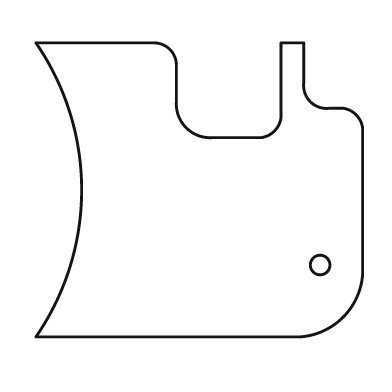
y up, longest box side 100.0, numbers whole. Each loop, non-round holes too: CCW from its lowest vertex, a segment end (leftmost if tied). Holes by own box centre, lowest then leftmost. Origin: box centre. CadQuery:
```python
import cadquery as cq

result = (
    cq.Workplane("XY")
    .moveTo(-50.0, -45.0)
    .lineTo(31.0, -45.0)
    .threePointArc((44.0, -39.0), (50.0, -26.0))
    .lineTo(50.0, 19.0)
    .threePointArc((48.0, 23.0), (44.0, 25.0))
    .lineTo(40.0, 25.0)
    .threePointArc((34.0, 27.0), (32.0, 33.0))
    .lineTo(32.0, 45.0)
    .lineTo(25.0, 45.0)
    .lineTo(25.0, 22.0)
    .threePointArc((23.0, 18.0), (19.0, 16.0))
    .lineTo(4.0, 16.0)
    .threePointArc((-4.0, 19.0), (-7.0, 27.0))
    .lineTo(-7.0, 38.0)
    .threePointArc((-9.0, 43.0), (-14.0, 45.0))
    .lineTo(-50.0, 45.0)
    .threePointArc((-36.0, 0.0), (-50.0, -45.0))
    .close()
    .moveTo(37.0, -23.0)
    .circle(3.0)
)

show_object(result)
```